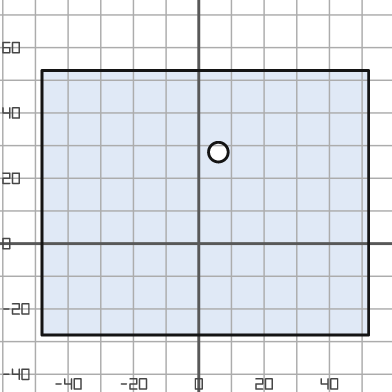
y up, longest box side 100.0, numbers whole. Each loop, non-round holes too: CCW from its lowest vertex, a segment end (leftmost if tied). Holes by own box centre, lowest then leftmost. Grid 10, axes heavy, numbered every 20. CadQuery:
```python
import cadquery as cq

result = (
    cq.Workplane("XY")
    .moveTo(-48.0, -28.0)
    .lineTo(52.0, -28.0)
    .lineTo(52.0, 53.0)
    .lineTo(-48.0, 53.0)
    .close()
    .moveTo(6.0, 28.0)
    .circle(3.0)
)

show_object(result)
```